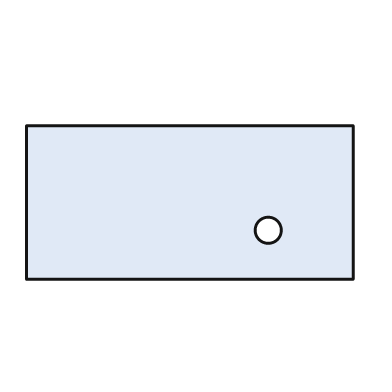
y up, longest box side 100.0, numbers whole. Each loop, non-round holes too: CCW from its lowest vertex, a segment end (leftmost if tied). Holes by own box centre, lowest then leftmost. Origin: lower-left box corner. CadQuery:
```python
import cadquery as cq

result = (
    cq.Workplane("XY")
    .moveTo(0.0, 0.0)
    .lineTo(100.0, 0.0)
    .lineTo(100.0, 47.0)
    .lineTo(0.0, 47.0)
    .close()
    .moveTo(74.0, 15.0)
    .circle(4.0)
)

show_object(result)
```